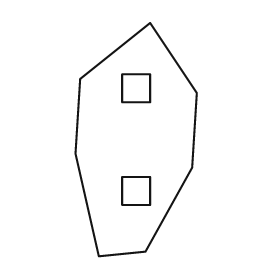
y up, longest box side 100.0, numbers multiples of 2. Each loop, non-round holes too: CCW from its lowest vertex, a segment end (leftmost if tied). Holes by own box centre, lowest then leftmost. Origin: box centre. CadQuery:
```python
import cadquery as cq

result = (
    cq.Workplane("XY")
    .moveTo(-16.0, -50.0)
    .lineTo(4.0, -48.0)
    .lineTo(24.0, -12.0)
    .lineTo(26.0, 20.0)
    .lineTo(6.0, 50.0)
    .lineTo(-24.0, 26.0)
    .lineTo(-26.0, -6.0)
    .close()
    .moveTo(-6.0, -28.0)
    .lineTo(6.0, -28.0)
    .lineTo(6.0, -16.0)
    .lineTo(-6.0, -16.0)
    .close()
    .moveTo(-6.0, 16.0)
    .lineTo(6.0, 16.0)
    .lineTo(6.0, 28.0)
    .lineTo(-6.0, 28.0)
    .close()
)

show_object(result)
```